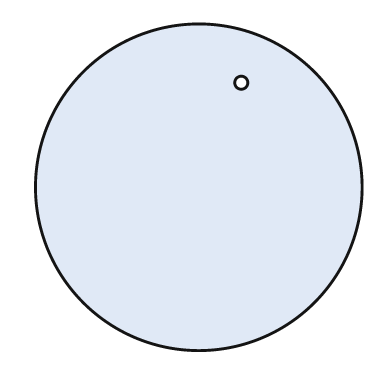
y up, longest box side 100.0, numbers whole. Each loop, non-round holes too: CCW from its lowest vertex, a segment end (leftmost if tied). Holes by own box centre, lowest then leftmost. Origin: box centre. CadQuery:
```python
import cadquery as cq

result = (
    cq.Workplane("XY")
    .moveTo(0.0, 0.0)
    .circle(50.0)
    .moveTo(13.0, 32.0)
    .circle(2.0)
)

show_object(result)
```